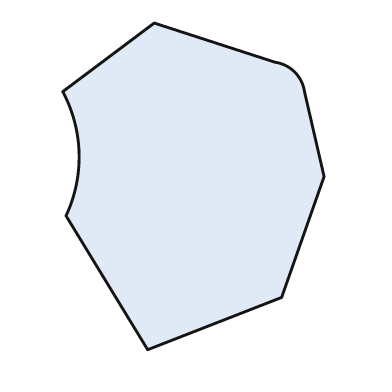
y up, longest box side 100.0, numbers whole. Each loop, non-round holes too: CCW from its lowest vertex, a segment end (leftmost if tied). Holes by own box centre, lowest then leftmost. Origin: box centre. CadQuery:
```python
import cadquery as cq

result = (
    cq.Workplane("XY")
    .moveTo(-14.0, -50.0)
    .lineTo(27.0, -34.0)
    .lineTo(40.0, 3.0)
    .lineTo(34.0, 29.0)
    .threePointArc((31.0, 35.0), (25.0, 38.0))
    .lineTo(-12.0, 50.0)
    .lineTo(-40.0, 29.0)
    .threePointArc((-35.0, 10.0), (-39.0, -9.0))
    .close()
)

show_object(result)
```